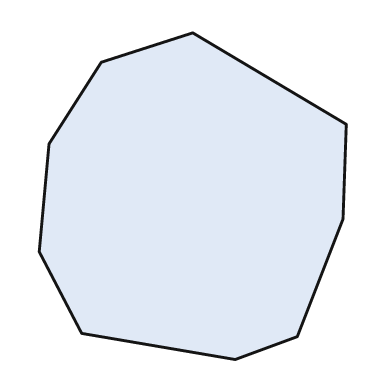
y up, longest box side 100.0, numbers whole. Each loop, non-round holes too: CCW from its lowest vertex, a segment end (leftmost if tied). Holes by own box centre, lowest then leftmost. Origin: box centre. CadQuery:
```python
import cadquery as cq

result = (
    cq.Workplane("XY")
    .moveTo(13.0, -50.0)
    .lineTo(32.0, -43.0)
    .lineTo(46.0, -7.0)
    .lineTo(47.0, 22.0)
    .lineTo(0.0, 50.0)
    .lineTo(-28.0, 41.0)
    .lineTo(-44.0, 16.0)
    .lineTo(-47.0, -17.0)
    .lineTo(-34.0, -42.0)
    .close()
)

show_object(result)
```